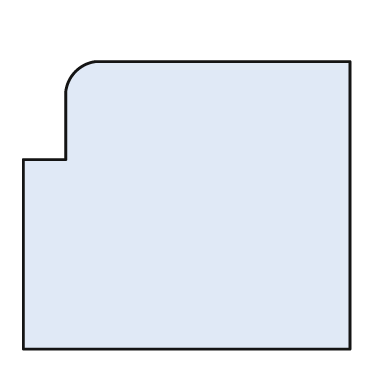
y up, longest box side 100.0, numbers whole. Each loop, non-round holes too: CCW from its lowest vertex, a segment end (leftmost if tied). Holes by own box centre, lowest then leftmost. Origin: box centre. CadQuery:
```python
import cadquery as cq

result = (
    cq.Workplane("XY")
    .moveTo(-50.0, -44.0)
    .lineTo(50.0, -44.0)
    .lineTo(50.0, 44.0)
    .lineTo(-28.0, 44.0)
    .threePointArc((-34.0, 41.0), (-37.0, 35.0))
    .lineTo(-37.0, 14.0)
    .lineTo(-50.0, 14.0)
    .close()
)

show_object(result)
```